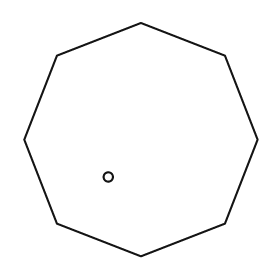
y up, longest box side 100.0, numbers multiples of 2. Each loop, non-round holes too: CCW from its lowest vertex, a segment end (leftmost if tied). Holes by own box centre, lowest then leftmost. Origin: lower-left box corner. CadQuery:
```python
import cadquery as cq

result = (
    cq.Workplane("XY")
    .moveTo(50.0, 0.0)
    .lineTo(86.0, 14.0)
    .lineTo(100.0, 50.0)
    .lineTo(86.0, 86.0)
    .lineTo(50.0, 100.0)
    .lineTo(14.0, 86.0)
    .lineTo(0.0, 50.0)
    .lineTo(14.0, 14.0)
    .close()
    .moveTo(36.0, 34.0)
    .circle(2.0)
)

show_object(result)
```